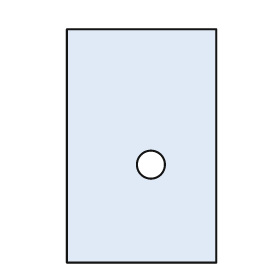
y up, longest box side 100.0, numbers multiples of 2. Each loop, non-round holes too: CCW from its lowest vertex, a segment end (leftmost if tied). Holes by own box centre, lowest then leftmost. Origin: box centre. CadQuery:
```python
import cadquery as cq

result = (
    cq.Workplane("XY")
    .moveTo(-32.0, -50.0)
    .lineTo(32.0, -50.0)
    .lineTo(32.0, 50.0)
    .lineTo(-32.0, 50.0)
    .close()
    .moveTo(4.0, -8.0)
    .circle(6.0)
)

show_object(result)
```